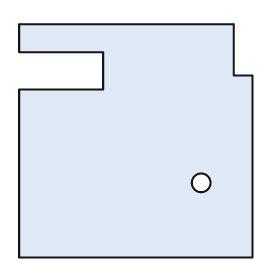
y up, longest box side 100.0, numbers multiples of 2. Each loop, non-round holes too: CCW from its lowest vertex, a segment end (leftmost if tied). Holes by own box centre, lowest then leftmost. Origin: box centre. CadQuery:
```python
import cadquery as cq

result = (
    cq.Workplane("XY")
    .moveTo(-50.0, -50.0)
    .lineTo(50.0, -50.0)
    .lineTo(50.0, 28.0)
    .lineTo(42.0, 28.0)
    .lineTo(42.0, 50.0)
    .lineTo(-50.0, 50.0)
    .lineTo(-50.0, 38.0)
    .lineTo(-14.0, 38.0)
    .lineTo(-14.0, 22.0)
    .lineTo(-50.0, 22.0)
    .close()
    .moveTo(28.0, -18.0)
    .circle(4.0)
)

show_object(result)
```